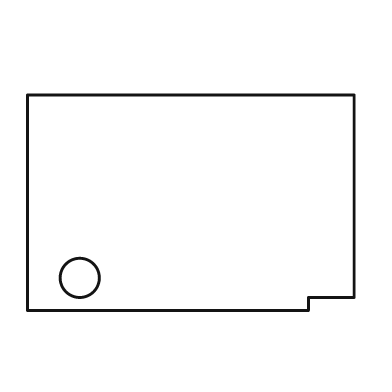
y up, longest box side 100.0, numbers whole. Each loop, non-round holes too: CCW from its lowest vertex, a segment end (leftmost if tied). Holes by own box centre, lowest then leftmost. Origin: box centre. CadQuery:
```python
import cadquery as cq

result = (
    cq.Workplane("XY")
    .moveTo(-50.0, -33.0)
    .lineTo(36.0, -33.0)
    .lineTo(36.0, -29.0)
    .lineTo(50.0, -29.0)
    .lineTo(50.0, 33.0)
    .lineTo(-50.0, 33.0)
    .close()
    .moveTo(-34.0, -23.0)
    .circle(6.0)
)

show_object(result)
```